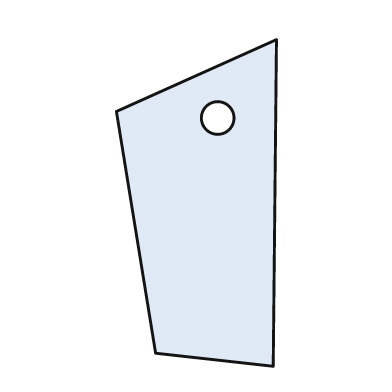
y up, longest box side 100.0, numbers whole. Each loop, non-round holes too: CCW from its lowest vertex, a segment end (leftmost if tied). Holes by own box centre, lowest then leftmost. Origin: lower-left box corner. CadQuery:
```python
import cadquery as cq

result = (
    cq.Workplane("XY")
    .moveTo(48.0, 0.0)
    .lineTo(49.0, 100.0)
    .lineTo(0.0, 78.0)
    .lineTo(12.0, 4.0)
    .close()
    .moveTo(31.0, 76.0)
    .circle(5.0)
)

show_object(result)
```